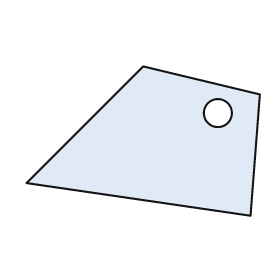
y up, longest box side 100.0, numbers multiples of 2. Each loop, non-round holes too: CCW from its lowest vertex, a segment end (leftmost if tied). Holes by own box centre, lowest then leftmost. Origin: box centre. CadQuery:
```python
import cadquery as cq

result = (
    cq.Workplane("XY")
    .moveTo(46.0, -32.0)
    .lineTo(50.0, 20.0)
    .lineTo(0.0, 32.0)
    .lineTo(-50.0, -18.0)
    .close()
    .moveTo(32.0, 12.0)
    .circle(6.0)
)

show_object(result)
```